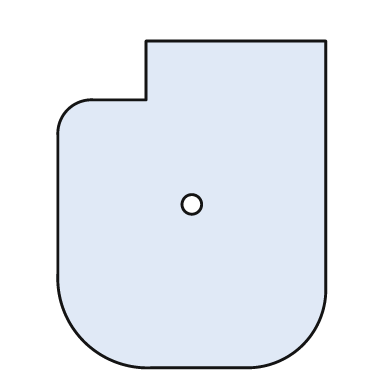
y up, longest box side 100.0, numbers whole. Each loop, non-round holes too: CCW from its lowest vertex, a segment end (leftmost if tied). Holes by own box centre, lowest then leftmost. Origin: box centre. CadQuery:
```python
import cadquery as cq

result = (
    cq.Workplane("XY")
    .moveTo(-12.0, -50.0)
    .lineTo(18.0, -50.0)
    .threePointArc((34.0, -43.0), (41.0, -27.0))
    .lineTo(41.0, 50.0)
    .lineTo(-14.0, 50.0)
    .lineTo(-14.0, 32.0)
    .lineTo(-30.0, 32.0)
    .threePointArc((-38.0, 29.0), (-41.0, 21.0))
    .lineTo(-41.0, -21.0)
    .threePointArc((-33.0, -42.0), (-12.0, -50.0))
    .close()
    .moveTo(0.0, 0.0)
    .circle(3.0)
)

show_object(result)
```